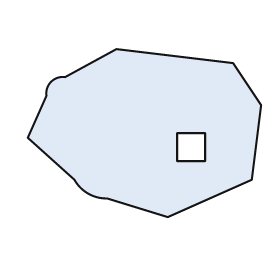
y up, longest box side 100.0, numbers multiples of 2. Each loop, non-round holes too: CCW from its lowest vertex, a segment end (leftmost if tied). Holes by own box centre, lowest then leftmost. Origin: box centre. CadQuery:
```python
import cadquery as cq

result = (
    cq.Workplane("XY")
    .moveTo(10.0, -36.0)
    .lineTo(46.0, -20.0)
    .lineTo(50.0, 12.0)
    .lineTo(38.0, 30.0)
    .lineTo(-12.0, 36.0)
    .lineTo(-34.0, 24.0)
    .threePointArc((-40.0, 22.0), (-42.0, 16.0))
    .lineTo(-50.0, -2.0)
    .lineTo(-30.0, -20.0)
    .threePointArc((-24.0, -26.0), (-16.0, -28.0))
    .close()
    .moveTo(14.0, -12.0)
    .lineTo(26.0, -12.0)
    .lineTo(26.0, 0.0)
    .lineTo(14.0, 0.0)
    .close()
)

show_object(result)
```